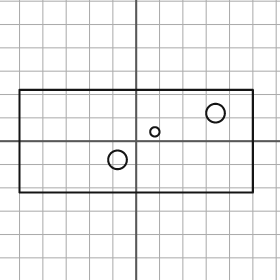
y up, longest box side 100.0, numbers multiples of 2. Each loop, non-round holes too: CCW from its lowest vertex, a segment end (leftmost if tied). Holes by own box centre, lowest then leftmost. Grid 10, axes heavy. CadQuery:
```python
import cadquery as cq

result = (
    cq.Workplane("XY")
    .moveTo(-50.0, -22.0)
    .lineTo(50.0, -22.0)
    .lineTo(50.0, 22.0)
    .lineTo(-50.0, 22.0)
    .close()
    .moveTo(-8.0, -8.0)
    .circle(4.0)
    .moveTo(8.0, 4.0)
    .circle(2.0)
    .moveTo(34.0, 12.0)
    .circle(4.0)
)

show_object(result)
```